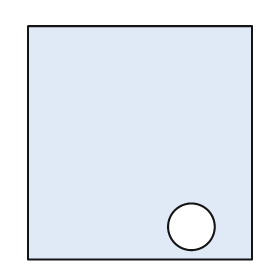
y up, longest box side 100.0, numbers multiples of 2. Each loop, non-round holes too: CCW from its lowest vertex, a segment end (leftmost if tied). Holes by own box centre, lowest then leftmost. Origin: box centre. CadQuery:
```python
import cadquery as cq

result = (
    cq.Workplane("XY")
    .moveTo(-48.0, -50.0)
    .lineTo(48.0, -50.0)
    .lineTo(48.0, 50.0)
    .lineTo(-48.0, 50.0)
    .close()
    .moveTo(22.0, -36.0)
    .circle(10.0)
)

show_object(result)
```